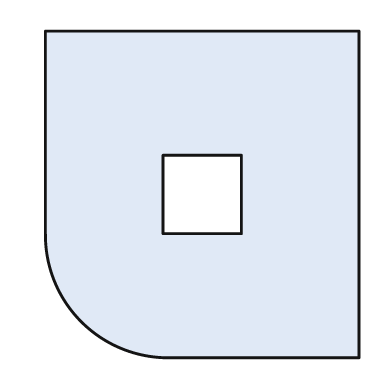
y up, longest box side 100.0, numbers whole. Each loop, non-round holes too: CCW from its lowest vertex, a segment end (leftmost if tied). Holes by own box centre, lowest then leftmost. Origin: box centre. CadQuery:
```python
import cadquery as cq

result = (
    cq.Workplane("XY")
    .moveTo(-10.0, -50.0)
    .lineTo(48.0, -50.0)
    .lineTo(48.0, 50.0)
    .lineTo(-48.0, 50.0)
    .lineTo(-48.0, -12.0)
    .threePointArc((-37.0, -39.0), (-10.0, -50.0))
    .close()
    .moveTo(-12.0, -12.0)
    .lineTo(12.0, -12.0)
    .lineTo(12.0, 12.0)
    .lineTo(-12.0, 12.0)
    .close()
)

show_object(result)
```